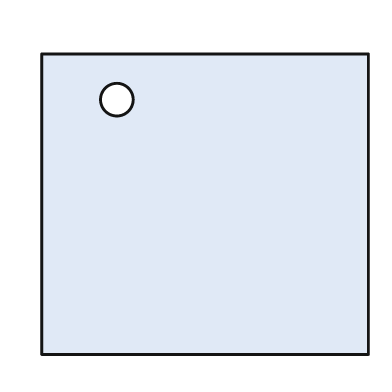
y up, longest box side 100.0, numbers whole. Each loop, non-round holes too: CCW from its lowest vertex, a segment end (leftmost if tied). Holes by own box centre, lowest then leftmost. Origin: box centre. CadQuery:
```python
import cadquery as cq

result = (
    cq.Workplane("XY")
    .moveTo(-50.0, -46.0)
    .lineTo(50.0, -46.0)
    .lineTo(50.0, 46.0)
    .lineTo(-50.0, 46.0)
    .close()
    .moveTo(-27.0, 32.0)
    .circle(5.0)
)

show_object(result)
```